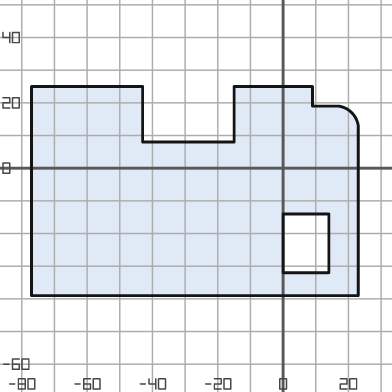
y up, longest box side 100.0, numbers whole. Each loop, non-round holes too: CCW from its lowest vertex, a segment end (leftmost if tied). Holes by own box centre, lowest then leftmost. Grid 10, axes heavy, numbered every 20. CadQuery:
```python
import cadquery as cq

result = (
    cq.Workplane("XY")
    .moveTo(-77.0, -39.0)
    .lineTo(23.0, -39.0)
    .lineTo(23.0, 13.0)
    .threePointArc((21.0, 17.0), (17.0, 19.0))
    .lineTo(9.0, 19.0)
    .lineTo(9.0, 25.0)
    .lineTo(-15.0, 25.0)
    .lineTo(-15.0, 8.0)
    .lineTo(-43.0, 8.0)
    .lineTo(-43.0, 25.0)
    .lineTo(-77.0, 25.0)
    .close()
    .moveTo(0.0, -32.0)
    .lineTo(14.0, -32.0)
    .lineTo(14.0, -14.0)
    .lineTo(0.0, -14.0)
    .close()
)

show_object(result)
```